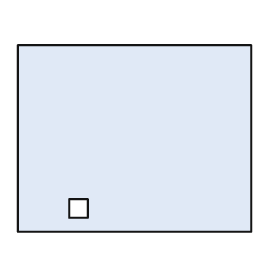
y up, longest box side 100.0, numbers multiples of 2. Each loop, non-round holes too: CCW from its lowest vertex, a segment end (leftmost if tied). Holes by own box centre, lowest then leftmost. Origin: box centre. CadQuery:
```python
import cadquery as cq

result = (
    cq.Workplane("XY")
    .moveTo(-50.0, -40.0)
    .lineTo(50.0, -40.0)
    .lineTo(50.0, 40.0)
    .lineTo(-50.0, 40.0)
    .close()
    .moveTo(-28.0, -34.0)
    .lineTo(-20.0, -34.0)
    .lineTo(-20.0, -26.0)
    .lineTo(-28.0, -26.0)
    .close()
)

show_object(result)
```